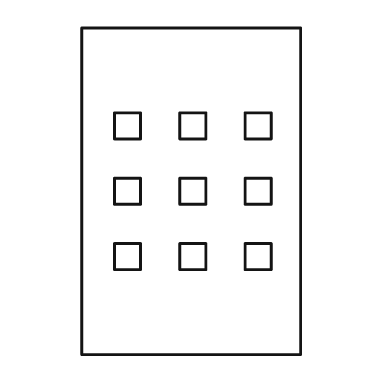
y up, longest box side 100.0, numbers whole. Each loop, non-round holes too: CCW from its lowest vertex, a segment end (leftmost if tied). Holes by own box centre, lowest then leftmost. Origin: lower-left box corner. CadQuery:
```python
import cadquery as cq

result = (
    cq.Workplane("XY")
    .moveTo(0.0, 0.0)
    .lineTo(67.0, 0.0)
    .lineTo(67.0, 100.0)
    .lineTo(0.0, 100.0)
    .close()
    .moveTo(10.0, 26.0)
    .lineTo(18.0, 26.0)
    .lineTo(18.0, 34.0)
    .lineTo(10.0, 34.0)
    .close()
    .moveTo(30.0, 26.0)
    .lineTo(38.0, 26.0)
    .lineTo(38.0, 34.0)
    .lineTo(30.0, 34.0)
    .close()
    .moveTo(50.0, 26.0)
    .lineTo(58.0, 26.0)
    .lineTo(58.0, 34.0)
    .lineTo(50.0, 34.0)
    .close()
    .moveTo(10.0, 46.0)
    .lineTo(18.0, 46.0)
    .lineTo(18.0, 54.0)
    .lineTo(10.0, 54.0)
    .close()
    .moveTo(30.0, 46.0)
    .lineTo(38.0, 46.0)
    .lineTo(38.0, 54.0)
    .lineTo(30.0, 54.0)
    .close()
    .moveTo(50.0, 46.0)
    .lineTo(58.0, 46.0)
    .lineTo(58.0, 54.0)
    .lineTo(50.0, 54.0)
    .close()
    .moveTo(10.0, 66.0)
    .lineTo(18.0, 66.0)
    .lineTo(18.0, 74.0)
    .lineTo(10.0, 74.0)
    .close()
    .moveTo(30.0, 66.0)
    .lineTo(38.0, 66.0)
    .lineTo(38.0, 74.0)
    .lineTo(30.0, 74.0)
    .close()
    .moveTo(50.0, 66.0)
    .lineTo(58.0, 66.0)
    .lineTo(58.0, 74.0)
    .lineTo(50.0, 74.0)
    .close()
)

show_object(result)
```